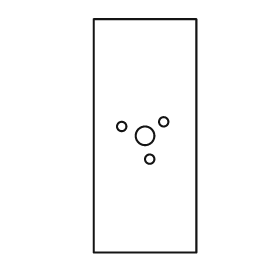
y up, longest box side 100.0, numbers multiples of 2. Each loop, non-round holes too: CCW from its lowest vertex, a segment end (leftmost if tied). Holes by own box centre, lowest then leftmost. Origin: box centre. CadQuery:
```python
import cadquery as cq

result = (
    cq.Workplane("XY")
    .moveTo(-22.0, -50.0)
    .lineTo(22.0, -50.0)
    .lineTo(22.0, 50.0)
    .lineTo(-22.0, 50.0)
    .close()
    .moveTo(2.0, -10.0)
    .circle(2.0)
    .moveTo(0.0, 0.0)
    .circle(4.0)
    .moveTo(-10.0, 4.0)
    .circle(2.0)
    .moveTo(8.0, 6.0)
    .circle(2.0)
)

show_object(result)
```